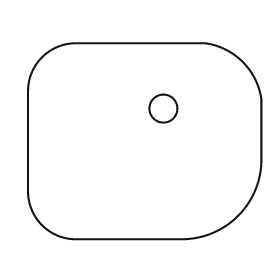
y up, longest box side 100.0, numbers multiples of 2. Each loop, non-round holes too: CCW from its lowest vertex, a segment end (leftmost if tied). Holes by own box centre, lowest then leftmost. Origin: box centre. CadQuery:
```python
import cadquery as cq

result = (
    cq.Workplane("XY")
    .moveTo(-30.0, -42.0)
    .lineTo(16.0, -42.0)
    .threePointArc((40.0, -32.0), (50.0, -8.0))
    .lineTo(50.0, 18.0)
    .threePointArc((42.0, 34.0), (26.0, 42.0))
    .lineTo(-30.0, 42.0)
    .threePointArc((-44.0, 36.0), (-50.0, 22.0))
    .lineTo(-50.0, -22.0)
    .threePointArc((-44.0, -36.0), (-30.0, -42.0))
    .close()
    .moveTo(8.0, 14.0)
    .circle(6.0)
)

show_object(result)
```